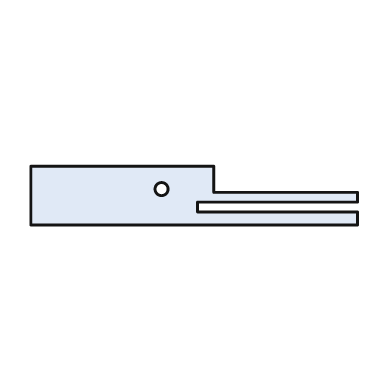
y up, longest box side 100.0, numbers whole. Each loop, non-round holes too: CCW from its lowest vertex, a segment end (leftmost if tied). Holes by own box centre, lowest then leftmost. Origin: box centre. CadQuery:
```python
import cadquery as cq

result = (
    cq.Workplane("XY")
    .moveTo(-50.0, -9.0)
    .lineTo(50.0, -9.0)
    .lineTo(50.0, -5.0)
    .lineTo(1.0, -5.0)
    .lineTo(1.0, -2.0)
    .lineTo(50.0, -2.0)
    .lineTo(50.0, 1.0)
    .lineTo(6.0, 1.0)
    .lineTo(6.0, 9.0)
    .lineTo(-50.0, 9.0)
    .close()
    .moveTo(-10.0, 2.0)
    .circle(2.0)
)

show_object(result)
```